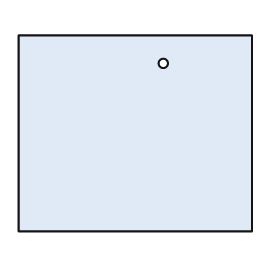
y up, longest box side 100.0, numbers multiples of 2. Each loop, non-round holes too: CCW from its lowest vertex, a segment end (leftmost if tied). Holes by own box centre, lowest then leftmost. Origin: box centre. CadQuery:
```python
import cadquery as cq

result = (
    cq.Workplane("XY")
    .moveTo(-50.0, -42.0)
    .lineTo(50.0, -42.0)
    .lineTo(50.0, 42.0)
    .lineTo(-50.0, 42.0)
    .close()
    .moveTo(12.0, 30.0)
    .circle(2.0)
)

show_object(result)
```